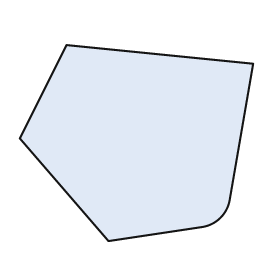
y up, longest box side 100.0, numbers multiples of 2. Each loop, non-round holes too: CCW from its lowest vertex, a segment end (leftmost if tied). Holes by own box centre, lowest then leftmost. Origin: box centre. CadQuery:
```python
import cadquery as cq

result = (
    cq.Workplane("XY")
    .moveTo(-12.0, -42.0)
    .lineTo(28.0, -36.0)
    .threePointArc((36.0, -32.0), (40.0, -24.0))
    .lineTo(50.0, 34.0)
    .lineTo(-30.0, 42.0)
    .lineTo(-50.0, 2.0)
    .close()
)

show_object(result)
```